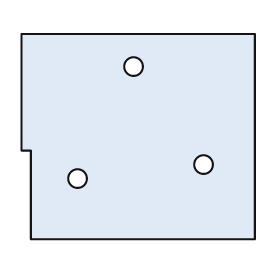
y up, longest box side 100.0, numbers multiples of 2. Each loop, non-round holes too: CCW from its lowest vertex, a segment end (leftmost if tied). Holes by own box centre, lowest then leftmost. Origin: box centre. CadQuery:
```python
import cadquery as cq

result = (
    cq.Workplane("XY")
    .moveTo(-46.0, -44.0)
    .lineTo(50.0, -44.0)
    .lineTo(50.0, 44.0)
    .lineTo(-50.0, 44.0)
    .lineTo(-50.0, -6.0)
    .lineTo(-46.0, -6.0)
    .close()
    .moveTo(-26.0, -18.0)
    .circle(4.0)
    .moveTo(28.0, -12.0)
    .circle(4.0)
    .moveTo(-2.0, 30.0)
    .circle(4.0)
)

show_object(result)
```